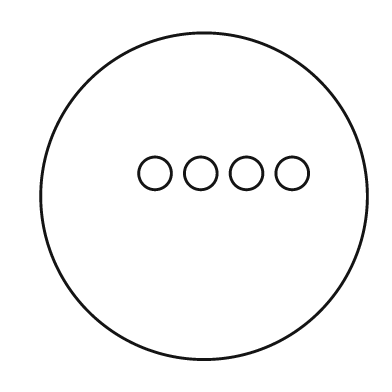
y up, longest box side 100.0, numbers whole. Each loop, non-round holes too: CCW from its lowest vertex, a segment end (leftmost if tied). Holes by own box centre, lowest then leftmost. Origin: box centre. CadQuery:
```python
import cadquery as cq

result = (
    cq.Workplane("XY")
    .moveTo(0.0, 0.0)
    .circle(50.0)
    .moveTo(-15.0, 7.0)
    .circle(5.0)
    .moveTo(-1.0, 7.0)
    .circle(5.0)
    .moveTo(13.0, 7.0)
    .circle(5.0)
    .moveTo(27.0, 7.0)
    .circle(5.0)
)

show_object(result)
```